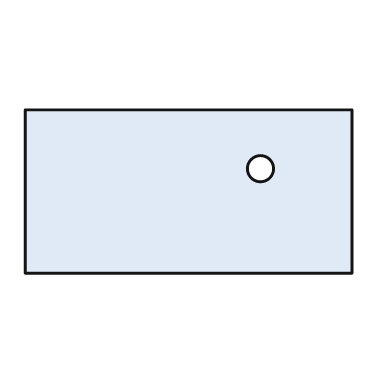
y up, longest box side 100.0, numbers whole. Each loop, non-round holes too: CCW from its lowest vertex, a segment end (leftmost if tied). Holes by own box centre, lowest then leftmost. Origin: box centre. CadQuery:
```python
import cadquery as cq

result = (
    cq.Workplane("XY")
    .moveTo(-50.0, -25.0)
    .lineTo(50.0, -25.0)
    .lineTo(50.0, 25.0)
    .lineTo(-50.0, 25.0)
    .close()
    .moveTo(22.0, 7.0)
    .circle(4.0)
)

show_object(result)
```